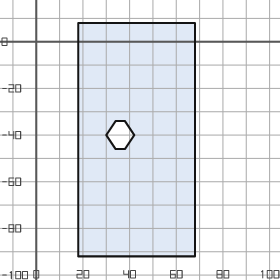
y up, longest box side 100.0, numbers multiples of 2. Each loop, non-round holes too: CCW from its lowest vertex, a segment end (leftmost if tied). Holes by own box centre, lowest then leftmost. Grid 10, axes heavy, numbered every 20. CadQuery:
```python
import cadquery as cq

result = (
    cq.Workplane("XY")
    .moveTo(18.0, -92.0)
    .lineTo(68.0, -92.0)
    .lineTo(68.0, 8.0)
    .lineTo(18.0, 8.0)
    .close()
    .moveTo(34.0, -46.0)
    .lineTo(38.0, -46.0)
    .lineTo(42.0, -40.0)
    .lineTo(38.0, -34.0)
    .lineTo(34.0, -34.0)
    .lineTo(30.0, -40.0)
    .close()
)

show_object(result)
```